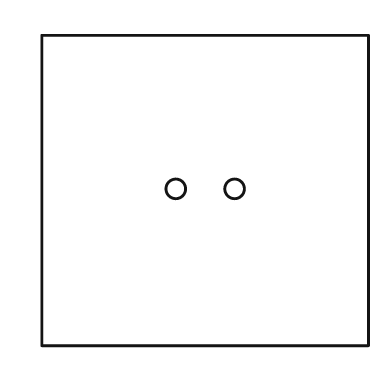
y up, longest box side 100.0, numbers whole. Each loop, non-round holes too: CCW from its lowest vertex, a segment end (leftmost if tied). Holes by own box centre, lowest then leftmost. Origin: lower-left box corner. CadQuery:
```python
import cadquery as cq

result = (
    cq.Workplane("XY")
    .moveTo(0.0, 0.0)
    .lineTo(100.0, 0.0)
    .lineTo(100.0, 95.0)
    .lineTo(0.0, 95.0)
    .close()
    .moveTo(41.0, 48.0)
    .circle(3.0)
    .moveTo(59.0, 48.0)
    .circle(3.0)
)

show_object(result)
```